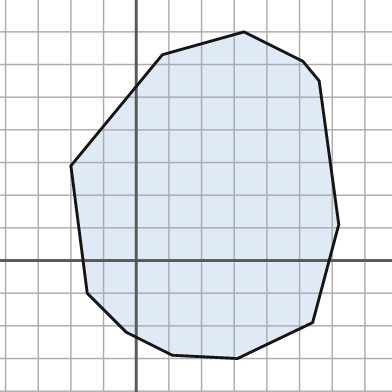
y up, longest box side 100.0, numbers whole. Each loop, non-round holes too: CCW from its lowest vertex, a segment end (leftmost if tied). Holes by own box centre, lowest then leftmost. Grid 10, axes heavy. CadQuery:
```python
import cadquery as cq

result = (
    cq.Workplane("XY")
    .moveTo(31.0, -30.0)
    .lineTo(54.0, -19.0)
    .lineTo(62.0, 11.0)
    .lineTo(56.0, 55.0)
    .lineTo(51.0, 61.0)
    .lineTo(33.0, 70.0)
    .lineTo(8.0, 63.0)
    .lineTo(-20.0, 29.0)
    .lineTo(-15.0, -10.0)
    .lineTo(-3.0, -22.0)
    .lineTo(11.0, -29.0)
    .close()
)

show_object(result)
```